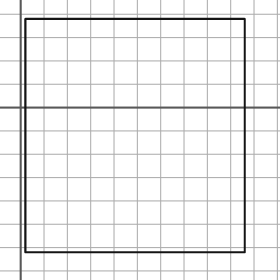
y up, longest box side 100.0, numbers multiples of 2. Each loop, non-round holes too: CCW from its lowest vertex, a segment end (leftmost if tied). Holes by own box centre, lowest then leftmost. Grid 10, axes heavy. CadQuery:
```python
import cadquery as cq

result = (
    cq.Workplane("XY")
    .moveTo(2.0, -62.0)
    .lineTo(96.0, -62.0)
    .lineTo(96.0, 38.0)
    .lineTo(2.0, 38.0)
    .close()
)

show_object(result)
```